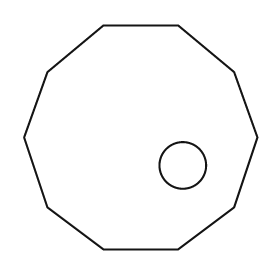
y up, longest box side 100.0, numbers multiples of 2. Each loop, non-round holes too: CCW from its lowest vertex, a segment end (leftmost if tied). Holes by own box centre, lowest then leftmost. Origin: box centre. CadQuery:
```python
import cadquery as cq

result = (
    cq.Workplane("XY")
    .moveTo(-16.0, -48.0)
    .lineTo(16.0, -48.0)
    .lineTo(40.0, -30.0)
    .lineTo(50.0, 0.0)
    .lineTo(40.0, 28.0)
    .lineTo(16.0, 48.0)
    .lineTo(-16.0, 48.0)
    .lineTo(-40.0, 28.0)
    .lineTo(-50.0, 0.0)
    .lineTo(-40.0, -30.0)
    .close()
    .moveTo(18.0, -12.0)
    .circle(10.0)
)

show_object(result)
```